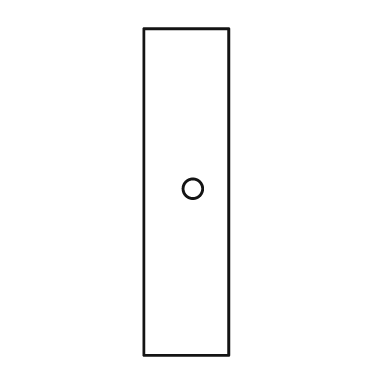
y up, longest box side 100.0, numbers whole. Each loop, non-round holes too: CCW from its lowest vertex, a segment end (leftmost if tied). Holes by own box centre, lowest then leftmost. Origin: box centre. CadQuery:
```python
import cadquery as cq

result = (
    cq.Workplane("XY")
    .moveTo(-13.0, -50.0)
    .lineTo(13.0, -50.0)
    .lineTo(13.0, 50.0)
    .lineTo(-13.0, 50.0)
    .close()
    .moveTo(2.0, 1.0)
    .circle(3.0)
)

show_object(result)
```